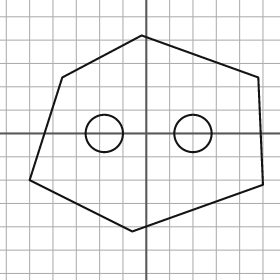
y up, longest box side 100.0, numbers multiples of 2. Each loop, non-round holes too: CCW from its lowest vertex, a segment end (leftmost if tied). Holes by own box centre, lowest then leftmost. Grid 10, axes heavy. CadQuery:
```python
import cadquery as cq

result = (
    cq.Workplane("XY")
    .moveTo(-6.0, -42.0)
    .lineTo(50.0, -22.0)
    .lineTo(48.0, 24.0)
    .lineTo(-2.0, 42.0)
    .lineTo(-36.0, 24.0)
    .lineTo(-50.0, -20.0)
    .close()
    .moveTo(-18.0, 0.0)
    .circle(8.0)
    .moveTo(20.0, 0.0)
    .circle(8.0)
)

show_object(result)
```